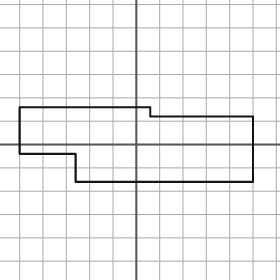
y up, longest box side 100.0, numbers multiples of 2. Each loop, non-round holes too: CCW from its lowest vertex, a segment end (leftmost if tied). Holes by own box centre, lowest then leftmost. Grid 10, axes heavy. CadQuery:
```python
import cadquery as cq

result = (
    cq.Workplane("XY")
    .moveTo(-26.0, -16.0)
    .lineTo(50.0, -16.0)
    .lineTo(50.0, 12.0)
    .lineTo(6.0, 12.0)
    .lineTo(6.0, 16.0)
    .lineTo(-50.0, 16.0)
    .lineTo(-50.0, -4.0)
    .lineTo(-26.0, -4.0)
    .close()
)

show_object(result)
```